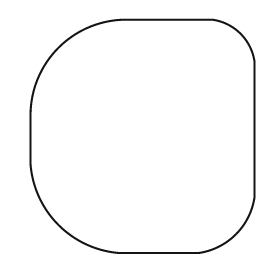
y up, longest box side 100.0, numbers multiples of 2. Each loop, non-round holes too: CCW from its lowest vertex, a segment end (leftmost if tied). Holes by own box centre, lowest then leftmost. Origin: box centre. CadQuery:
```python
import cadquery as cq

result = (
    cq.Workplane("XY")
    .moveTo(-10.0, -50.0)
    .lineTo(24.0, -50.0)
    .threePointArc((40.0, -42.0), (48.0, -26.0))
    .lineTo(48.0, 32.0)
    .threePointArc((42.0, 44.0), (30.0, 50.0))
    .lineTo(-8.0, 50.0)
    .threePointArc((-36.0, 38.0), (-48.0, 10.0))
    .lineTo(-48.0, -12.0)
    .threePointArc((-36.0, -38.0), (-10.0, -50.0))
    .close()
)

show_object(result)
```